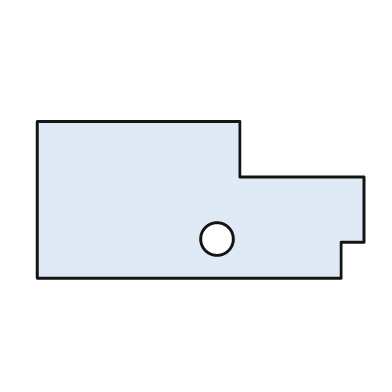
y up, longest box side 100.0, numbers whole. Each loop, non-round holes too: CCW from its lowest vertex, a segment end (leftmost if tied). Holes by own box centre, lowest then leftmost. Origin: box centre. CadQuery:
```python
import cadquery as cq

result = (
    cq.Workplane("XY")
    .moveTo(-50.0, -24.0)
    .lineTo(43.0, -24.0)
    .lineTo(43.0, -13.0)
    .lineTo(50.0, -13.0)
    .lineTo(50.0, 7.0)
    .lineTo(12.0, 7.0)
    .lineTo(12.0, 24.0)
    .lineTo(-50.0, 24.0)
    .close()
    .moveTo(5.0, -12.0)
    .circle(5.0)
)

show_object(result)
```